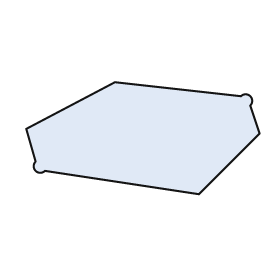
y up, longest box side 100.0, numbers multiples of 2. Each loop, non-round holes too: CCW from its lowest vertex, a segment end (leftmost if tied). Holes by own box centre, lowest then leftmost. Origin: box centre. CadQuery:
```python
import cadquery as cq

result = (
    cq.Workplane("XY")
    .moveTo(24.0, -24.0)
    .lineTo(50.0, 2.0)
    .lineTo(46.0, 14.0)
    .threePointArc((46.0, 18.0), (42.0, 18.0))
    .lineTo(-12.0, 24.0)
    .lineTo(-50.0, 4.0)
    .lineTo(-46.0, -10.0)
    .threePointArc((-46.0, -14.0), (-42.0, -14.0))
    .close()
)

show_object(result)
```